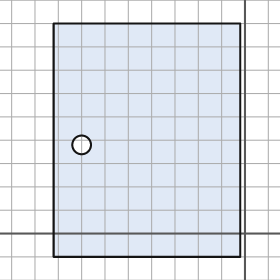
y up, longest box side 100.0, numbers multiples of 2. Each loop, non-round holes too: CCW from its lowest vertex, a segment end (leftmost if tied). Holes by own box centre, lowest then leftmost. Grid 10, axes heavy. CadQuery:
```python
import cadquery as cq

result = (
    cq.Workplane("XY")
    .moveTo(-82.0, -10.0)
    .lineTo(-2.0, -10.0)
    .lineTo(-2.0, 90.0)
    .lineTo(-82.0, 90.0)
    .close()
    .moveTo(-70.0, 38.0)
    .circle(4.0)
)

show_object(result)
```